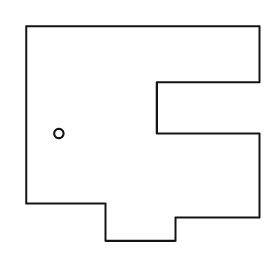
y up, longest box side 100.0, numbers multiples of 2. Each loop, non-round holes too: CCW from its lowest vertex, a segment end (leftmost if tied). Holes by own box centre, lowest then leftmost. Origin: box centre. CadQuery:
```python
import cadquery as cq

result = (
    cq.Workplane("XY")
    .moveTo(-16.0, -46.0)
    .lineTo(14.0, -46.0)
    .lineTo(14.0, -36.0)
    .lineTo(50.0, -36.0)
    .lineTo(50.0, 0.0)
    .lineTo(6.0, 0.0)
    .lineTo(6.0, 22.0)
    .lineTo(50.0, 22.0)
    .lineTo(50.0, 46.0)
    .lineTo(-50.0, 46.0)
    .lineTo(-50.0, -30.0)
    .lineTo(-16.0, -30.0)
    .close()
    .moveTo(-36.0, 0.0)
    .circle(2.0)
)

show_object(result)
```